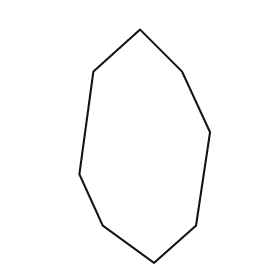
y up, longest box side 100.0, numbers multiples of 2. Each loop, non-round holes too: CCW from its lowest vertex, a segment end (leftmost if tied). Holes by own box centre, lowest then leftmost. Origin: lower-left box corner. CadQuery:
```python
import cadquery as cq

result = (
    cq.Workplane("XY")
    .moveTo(32.0, 0.0)
    .lineTo(50.0, 16.0)
    .lineTo(56.0, 56.0)
    .lineTo(44.0, 82.0)
    .lineTo(26.0, 100.0)
    .lineTo(6.0, 82.0)
    .lineTo(0.0, 38.0)
    .lineTo(10.0, 16.0)
    .close()
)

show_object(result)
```